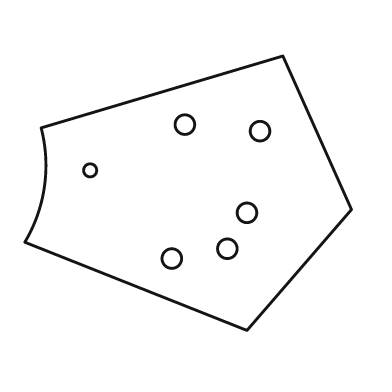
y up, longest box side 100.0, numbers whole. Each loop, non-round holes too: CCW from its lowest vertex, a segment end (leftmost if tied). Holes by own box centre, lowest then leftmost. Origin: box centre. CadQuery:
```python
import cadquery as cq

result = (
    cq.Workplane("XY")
    .moveTo(18.0, -42.0)
    .lineTo(50.0, -5.0)
    .lineTo(29.0, 42.0)
    .lineTo(-45.0, 20.0)
    .threePointArc((-44.0, 2.0), (-50.0, -15.0))
    .close()
    .moveTo(-5.0, -20.0)
    .circle(3.0)
    .moveTo(12.0, -17.0)
    .circle(3.0)
    .moveTo(18.0, -6.0)
    .circle(3.0)
    .moveTo(-30.0, 7.0)
    .circle(2.0)
    .moveTo(22.0, 19.0)
    .circle(3.0)
    .moveTo(-1.0, 21.0)
    .circle(3.0)
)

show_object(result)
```